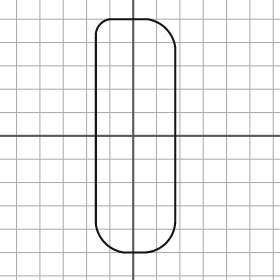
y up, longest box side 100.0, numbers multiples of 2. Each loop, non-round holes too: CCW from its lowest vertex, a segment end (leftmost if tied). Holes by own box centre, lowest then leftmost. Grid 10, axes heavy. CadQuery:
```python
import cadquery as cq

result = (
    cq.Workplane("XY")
    .moveTo(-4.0, -50.0)
    .lineTo(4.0, -50.0)
    .threePointArc((14.0, -46.0), (18.0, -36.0))
    .lineTo(18.0, 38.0)
    .threePointArc((14.0, 46.0), (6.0, 50.0))
    .lineTo(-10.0, 50.0)
    .threePointArc((-14.0, 48.0), (-16.0, 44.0))
    .lineTo(-16.0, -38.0)
    .threePointArc((-12.0, -46.0), (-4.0, -50.0))
    .close()
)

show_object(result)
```